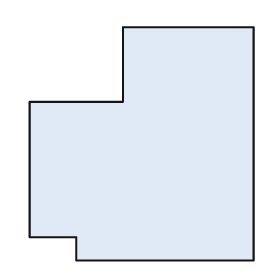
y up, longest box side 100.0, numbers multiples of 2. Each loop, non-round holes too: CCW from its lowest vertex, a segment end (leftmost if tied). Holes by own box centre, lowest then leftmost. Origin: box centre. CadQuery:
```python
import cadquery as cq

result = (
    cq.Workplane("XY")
    .moveTo(-28.0, -50.0)
    .lineTo(48.0, -50.0)
    .lineTo(48.0, 50.0)
    .lineTo(-8.0, 50.0)
    .lineTo(-8.0, 18.0)
    .lineTo(-48.0, 18.0)
    .lineTo(-48.0, -40.0)
    .lineTo(-28.0, -40.0)
    .close()
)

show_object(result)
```